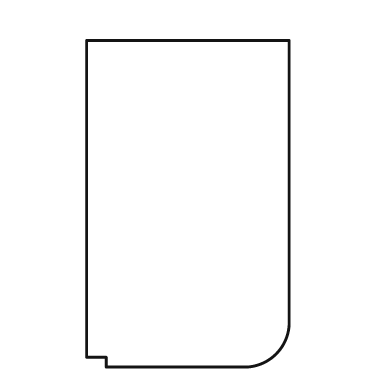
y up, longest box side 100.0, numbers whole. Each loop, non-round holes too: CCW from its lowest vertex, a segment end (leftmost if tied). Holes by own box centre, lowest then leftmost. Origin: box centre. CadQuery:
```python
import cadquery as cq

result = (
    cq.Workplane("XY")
    .moveTo(-25.0, -50.0)
    .lineTo(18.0, -50.0)
    .threePointArc((27.0, -46.0), (31.0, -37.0))
    .lineTo(31.0, 50.0)
    .lineTo(-31.0, 50.0)
    .lineTo(-31.0, -47.0)
    .lineTo(-25.0, -47.0)
    .close()
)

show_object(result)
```